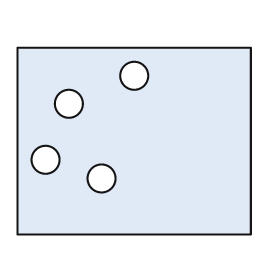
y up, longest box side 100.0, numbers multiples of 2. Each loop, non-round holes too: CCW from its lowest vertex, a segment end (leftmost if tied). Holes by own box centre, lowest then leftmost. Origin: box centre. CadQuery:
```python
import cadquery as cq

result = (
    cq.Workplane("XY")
    .moveTo(-50.0, -40.0)
    .lineTo(50.0, -40.0)
    .lineTo(50.0, 40.0)
    .lineTo(-50.0, 40.0)
    .close()
    .moveTo(-14.0, -16.0)
    .circle(6.0)
    .moveTo(-38.0, -8.0)
    .circle(6.0)
    .moveTo(-28.0, 16.0)
    .circle(6.0)
    .moveTo(0.0, 28.0)
    .circle(6.0)
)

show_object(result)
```